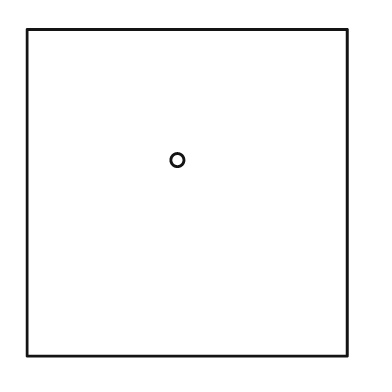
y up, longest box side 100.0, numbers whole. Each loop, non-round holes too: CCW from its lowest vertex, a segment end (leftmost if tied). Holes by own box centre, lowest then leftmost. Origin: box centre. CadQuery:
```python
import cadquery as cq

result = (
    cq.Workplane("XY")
    .moveTo(-49.0, -50.0)
    .lineTo(49.0, -50.0)
    .lineTo(49.0, 50.0)
    .lineTo(-49.0, 50.0)
    .close()
    .moveTo(-3.0, 10.0)
    .circle(2.0)
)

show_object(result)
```